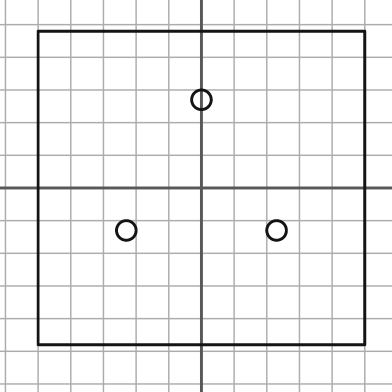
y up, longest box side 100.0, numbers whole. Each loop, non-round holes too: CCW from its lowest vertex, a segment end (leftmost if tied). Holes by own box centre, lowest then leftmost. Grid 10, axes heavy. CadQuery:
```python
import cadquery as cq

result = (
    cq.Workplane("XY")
    .moveTo(-50.0, -48.0)
    .lineTo(50.0, -48.0)
    .lineTo(50.0, 48.0)
    .lineTo(-50.0, 48.0)
    .close()
    .moveTo(-23.0, -13.0)
    .circle(3.0)
    .moveTo(23.0, -13.0)
    .circle(3.0)
    .moveTo(0.0, 27.0)
    .circle(3.0)
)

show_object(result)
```